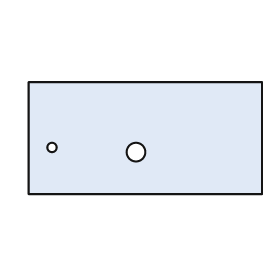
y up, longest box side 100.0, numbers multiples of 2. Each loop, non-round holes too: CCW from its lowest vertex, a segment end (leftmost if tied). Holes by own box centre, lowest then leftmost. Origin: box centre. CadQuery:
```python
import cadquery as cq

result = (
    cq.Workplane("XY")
    .moveTo(-50.0, -24.0)
    .lineTo(50.0, -24.0)
    .lineTo(50.0, 24.0)
    .lineTo(-50.0, 24.0)
    .close()
    .moveTo(-4.0, -6.0)
    .circle(4.0)
    .moveTo(-40.0, -4.0)
    .circle(2.0)
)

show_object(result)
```